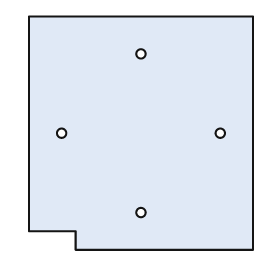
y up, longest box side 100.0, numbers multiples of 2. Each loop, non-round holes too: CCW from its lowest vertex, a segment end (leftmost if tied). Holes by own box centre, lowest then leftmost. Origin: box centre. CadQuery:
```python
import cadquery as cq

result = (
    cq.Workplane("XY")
    .moveTo(-28.0, -50.0)
    .lineTo(48.0, -50.0)
    .lineTo(48.0, 50.0)
    .lineTo(-48.0, 50.0)
    .lineTo(-48.0, -42.0)
    .lineTo(-28.0, -42.0)
    .close()
    .moveTo(0.0, -34.0)
    .circle(2.0)
    .moveTo(-34.0, 0.0)
    .circle(2.0)
    .moveTo(34.0, 0.0)
    .circle(2.0)
    .moveTo(0.0, 34.0)
    .circle(2.0)
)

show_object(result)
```